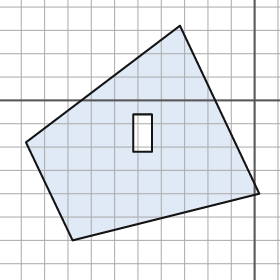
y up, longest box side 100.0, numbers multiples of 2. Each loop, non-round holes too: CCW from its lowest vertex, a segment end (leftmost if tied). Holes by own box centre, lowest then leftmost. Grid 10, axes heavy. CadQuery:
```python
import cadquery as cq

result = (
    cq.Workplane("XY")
    .moveTo(-78.0, -60.0)
    .lineTo(2.0, -40.0)
    .lineTo(-32.0, 32.0)
    .lineTo(-98.0, -18.0)
    .close()
    .moveTo(-52.0, -22.0)
    .lineTo(-44.0, -22.0)
    .lineTo(-44.0, -6.0)
    .lineTo(-52.0, -6.0)
    .close()
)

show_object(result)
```